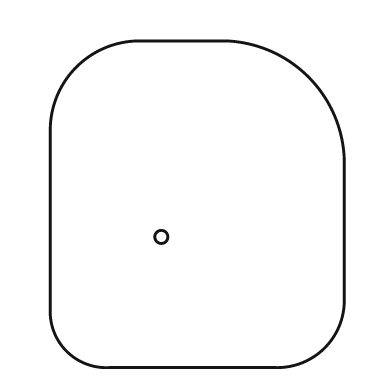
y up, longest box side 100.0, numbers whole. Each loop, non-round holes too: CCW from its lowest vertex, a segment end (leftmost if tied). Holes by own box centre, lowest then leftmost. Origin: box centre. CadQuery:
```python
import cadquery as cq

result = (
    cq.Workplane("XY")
    .moveTo(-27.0, -50.0)
    .lineTo(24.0, -50.0)
    .threePointArc((39.0, -44.0), (45.0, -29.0))
    .lineTo(45.0, 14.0)
    .threePointArc((34.0, 39.0), (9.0, 50.0))
    .lineTo(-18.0, 50.0)
    .threePointArc((-37.0, 42.0), (-45.0, 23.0))
    .lineTo(-45.0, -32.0)
    .threePointArc((-40.0, -45.0), (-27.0, -50.0))
    .close()
    .moveTo(-11.0, -10.0)
    .circle(2.0)
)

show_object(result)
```